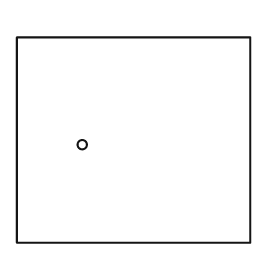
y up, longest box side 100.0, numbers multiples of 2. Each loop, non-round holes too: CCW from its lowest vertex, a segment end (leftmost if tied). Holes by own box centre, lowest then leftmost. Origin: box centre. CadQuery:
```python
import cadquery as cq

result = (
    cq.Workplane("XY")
    .moveTo(-50.0, -44.0)
    .lineTo(50.0, -44.0)
    .lineTo(50.0, 44.0)
    .lineTo(-50.0, 44.0)
    .close()
    .moveTo(-22.0, -2.0)
    .circle(2.0)
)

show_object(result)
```